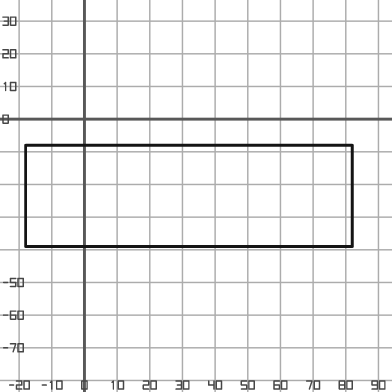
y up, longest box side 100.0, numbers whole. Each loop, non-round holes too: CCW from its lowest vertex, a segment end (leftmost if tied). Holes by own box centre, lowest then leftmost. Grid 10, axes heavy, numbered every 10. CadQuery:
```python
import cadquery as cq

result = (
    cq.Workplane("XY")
    .moveTo(-18.0, -39.0)
    .lineTo(82.0, -39.0)
    .lineTo(82.0, -8.0)
    .lineTo(-18.0, -8.0)
    .close()
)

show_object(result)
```